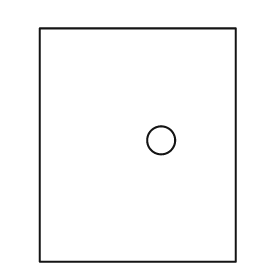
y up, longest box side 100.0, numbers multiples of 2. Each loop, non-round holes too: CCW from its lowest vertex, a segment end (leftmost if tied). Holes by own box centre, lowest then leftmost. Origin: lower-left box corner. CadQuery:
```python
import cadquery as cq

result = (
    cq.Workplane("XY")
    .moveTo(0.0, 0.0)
    .lineTo(84.0, 0.0)
    .lineTo(84.0, 100.0)
    .lineTo(0.0, 100.0)
    .close()
    .moveTo(52.0, 52.0)
    .circle(6.0)
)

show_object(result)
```